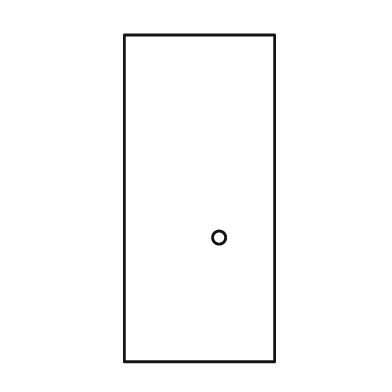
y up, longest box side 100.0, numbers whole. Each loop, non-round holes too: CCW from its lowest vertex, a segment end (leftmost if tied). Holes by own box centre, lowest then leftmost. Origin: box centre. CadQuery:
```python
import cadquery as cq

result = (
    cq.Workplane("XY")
    .moveTo(-23.0, -50.0)
    .lineTo(23.0, -50.0)
    .lineTo(23.0, 50.0)
    .lineTo(-23.0, 50.0)
    .close()
    .moveTo(6.0, -12.0)
    .circle(2.0)
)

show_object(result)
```